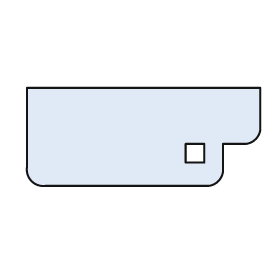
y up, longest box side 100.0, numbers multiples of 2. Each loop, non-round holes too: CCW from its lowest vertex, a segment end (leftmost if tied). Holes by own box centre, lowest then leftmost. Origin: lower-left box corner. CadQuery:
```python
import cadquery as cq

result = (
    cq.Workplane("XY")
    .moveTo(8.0, 0.0)
    .lineTo(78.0, 0.0)
    .threePointArc((82.0, 2.0), (84.0, 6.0))
    .lineTo(84.0, 18.0)
    .lineTo(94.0, 18.0)
    .threePointArc((98.0, 20.0), (100.0, 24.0))
    .lineTo(100.0, 42.0)
    .lineTo(0.0, 42.0)
    .lineTo(0.0, 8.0)
    .threePointArc((2.0, 2.0), (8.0, 0.0))
    .close()
    .moveTo(68.0, 10.0)
    .lineTo(76.0, 10.0)
    .lineTo(76.0, 18.0)
    .lineTo(68.0, 18.0)
    .close()
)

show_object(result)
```